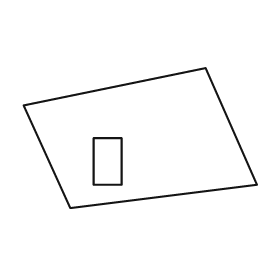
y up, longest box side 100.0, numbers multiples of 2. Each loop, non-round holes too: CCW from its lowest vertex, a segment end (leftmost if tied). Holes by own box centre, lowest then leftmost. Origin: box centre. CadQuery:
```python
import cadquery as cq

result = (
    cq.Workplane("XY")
    .moveTo(-30.0, -30.0)
    .lineTo(50.0, -20.0)
    .lineTo(28.0, 30.0)
    .lineTo(-50.0, 14.0)
    .close()
    .moveTo(-20.0, -20.0)
    .lineTo(-8.0, -20.0)
    .lineTo(-8.0, 0.0)
    .lineTo(-20.0, 0.0)
    .close()
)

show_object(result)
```